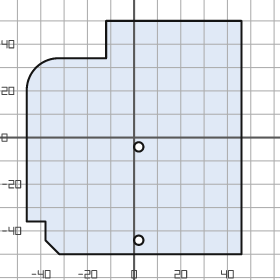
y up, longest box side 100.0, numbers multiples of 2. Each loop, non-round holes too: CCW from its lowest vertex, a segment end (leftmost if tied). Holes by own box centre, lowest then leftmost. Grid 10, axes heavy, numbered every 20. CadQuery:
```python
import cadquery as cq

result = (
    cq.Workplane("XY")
    .moveTo(-32.0, -50.0)
    .lineTo(46.0, -50.0)
    .lineTo(46.0, 50.0)
    .lineTo(-12.0, 50.0)
    .lineTo(-12.0, 34.0)
    .lineTo(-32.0, 34.0)
    .threePointArc((-42.0, 30.0), (-46.0, 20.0))
    .lineTo(-46.0, -36.0)
    .lineTo(-38.0, -36.0)
    .lineTo(-38.0, -44.0)
    .close()
    .moveTo(2.0, -44.0)
    .circle(2.0)
    .moveTo(2.0, -4.0)
    .circle(2.0)
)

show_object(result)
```